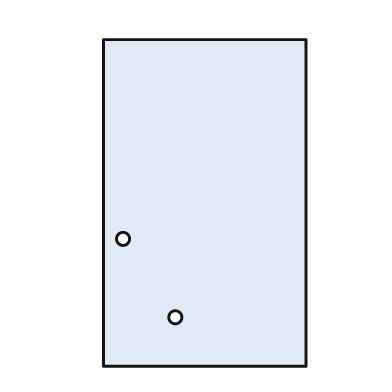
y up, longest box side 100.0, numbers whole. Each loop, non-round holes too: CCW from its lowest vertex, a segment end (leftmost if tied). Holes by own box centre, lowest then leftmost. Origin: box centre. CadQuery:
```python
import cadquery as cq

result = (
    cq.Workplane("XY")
    .moveTo(-31.0, -50.0)
    .lineTo(31.0, -50.0)
    .lineTo(31.0, 50.0)
    .lineTo(-31.0, 50.0)
    .close()
    .moveTo(-9.0, -35.0)
    .circle(2.0)
    .moveTo(-25.0, -11.0)
    .circle(2.0)
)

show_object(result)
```